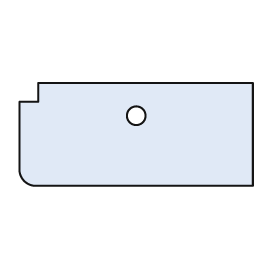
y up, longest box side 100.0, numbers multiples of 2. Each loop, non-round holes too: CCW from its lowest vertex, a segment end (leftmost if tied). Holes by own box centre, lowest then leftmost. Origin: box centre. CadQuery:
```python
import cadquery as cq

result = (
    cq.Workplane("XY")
    .moveTo(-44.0, -22.0)
    .lineTo(50.0, -22.0)
    .lineTo(50.0, 22.0)
    .lineTo(-42.0, 22.0)
    .lineTo(-42.0, 14.0)
    .lineTo(-50.0, 14.0)
    .lineTo(-50.0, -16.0)
    .threePointArc((-48.0, -20.0), (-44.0, -22.0))
    .close()
    .moveTo(0.0, 8.0)
    .circle(4.0)
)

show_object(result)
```